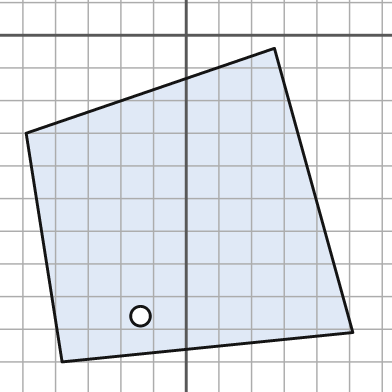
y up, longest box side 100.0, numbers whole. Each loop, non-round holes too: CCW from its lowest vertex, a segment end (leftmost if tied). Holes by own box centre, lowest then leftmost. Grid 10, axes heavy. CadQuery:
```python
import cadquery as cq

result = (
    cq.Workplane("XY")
    .moveTo(-38.0, -100.0)
    .lineTo(51.0, -91.0)
    .lineTo(27.0, -4.0)
    .lineTo(-49.0, -30.0)
    .close()
    .moveTo(-14.0, -86.0)
    .circle(3.0)
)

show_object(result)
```